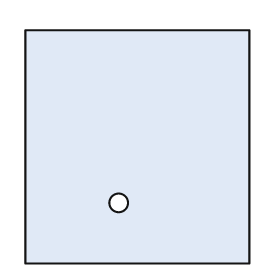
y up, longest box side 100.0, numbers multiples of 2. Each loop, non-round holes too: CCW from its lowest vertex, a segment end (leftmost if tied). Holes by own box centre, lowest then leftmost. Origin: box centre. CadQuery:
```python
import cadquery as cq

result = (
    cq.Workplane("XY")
    .moveTo(-48.0, -50.0)
    .lineTo(48.0, -50.0)
    .lineTo(48.0, 50.0)
    .lineTo(-48.0, 50.0)
    .close()
    .moveTo(-8.0, -24.0)
    .circle(4.0)
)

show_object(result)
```